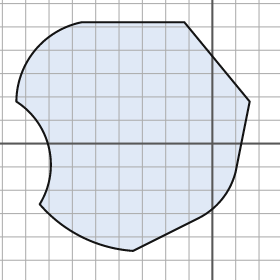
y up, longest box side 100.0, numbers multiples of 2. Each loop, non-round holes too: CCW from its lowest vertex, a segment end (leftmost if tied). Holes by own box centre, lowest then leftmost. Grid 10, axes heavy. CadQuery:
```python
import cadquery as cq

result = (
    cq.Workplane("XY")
    .moveTo(-34.0, -46.0)
    .lineTo(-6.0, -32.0)
    .threePointArc((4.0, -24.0), (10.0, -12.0))
    .lineTo(16.0, 18.0)
    .lineTo(-12.0, 52.0)
    .lineTo(-56.0, 52.0)
    .threePointArc((-76.0, 40.0), (-84.0, 18.0))
    .threePointArc((-70.0, -2.0), (-74.0, -26.0))
    .threePointArc((-56.0, -40.0), (-34.0, -46.0))
    .close()
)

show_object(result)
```